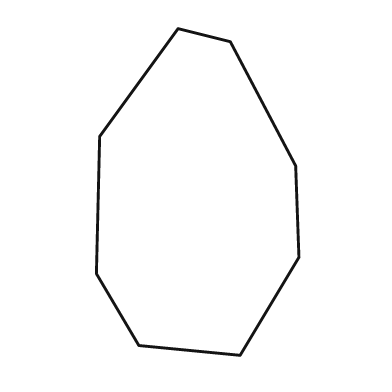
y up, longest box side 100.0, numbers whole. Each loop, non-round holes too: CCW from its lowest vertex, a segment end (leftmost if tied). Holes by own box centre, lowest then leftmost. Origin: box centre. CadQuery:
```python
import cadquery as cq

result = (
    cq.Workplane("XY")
    .moveTo(13.0, -50.0)
    .lineTo(31.0, -20.0)
    .lineTo(30.0, 8.0)
    .lineTo(10.0, 46.0)
    .lineTo(-6.0, 50.0)
    .lineTo(-30.0, 17.0)
    .lineTo(-31.0, -25.0)
    .lineTo(-18.0, -47.0)
    .close()
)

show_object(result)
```